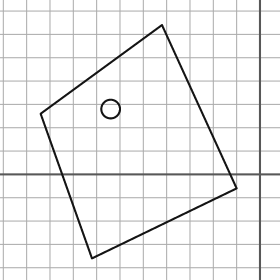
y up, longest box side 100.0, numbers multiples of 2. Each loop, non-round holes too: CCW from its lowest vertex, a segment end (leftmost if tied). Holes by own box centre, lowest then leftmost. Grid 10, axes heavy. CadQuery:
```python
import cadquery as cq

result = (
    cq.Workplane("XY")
    .moveTo(-72.0, -36.0)
    .lineTo(-10.0, -6.0)
    .lineTo(-42.0, 64.0)
    .lineTo(-94.0, 26.0)
    .close()
    .moveTo(-64.0, 28.0)
    .circle(4.0)
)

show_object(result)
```